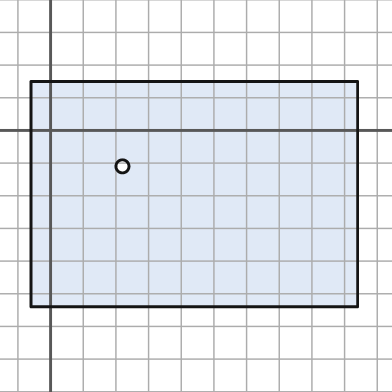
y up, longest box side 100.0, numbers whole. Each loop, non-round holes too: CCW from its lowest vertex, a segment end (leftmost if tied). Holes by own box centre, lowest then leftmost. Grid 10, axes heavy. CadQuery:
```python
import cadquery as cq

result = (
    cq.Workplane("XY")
    .moveTo(-6.0, -54.0)
    .lineTo(94.0, -54.0)
    .lineTo(94.0, 15.0)
    .lineTo(-6.0, 15.0)
    .close()
    .moveTo(22.0, -11.0)
    .circle(2.0)
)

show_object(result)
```